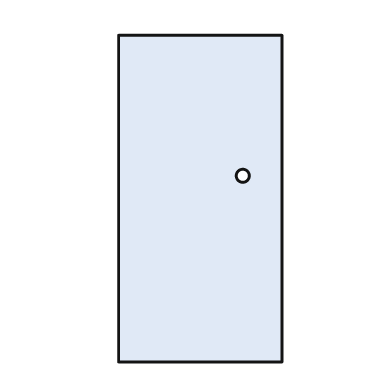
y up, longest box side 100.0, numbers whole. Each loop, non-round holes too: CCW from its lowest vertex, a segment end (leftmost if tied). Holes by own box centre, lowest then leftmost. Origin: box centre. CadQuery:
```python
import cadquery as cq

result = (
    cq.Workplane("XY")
    .moveTo(-25.0, -50.0)
    .lineTo(25.0, -50.0)
    .lineTo(25.0, 50.0)
    .lineTo(-25.0, 50.0)
    .close()
    .moveTo(13.0, 7.0)
    .circle(2.0)
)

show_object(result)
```